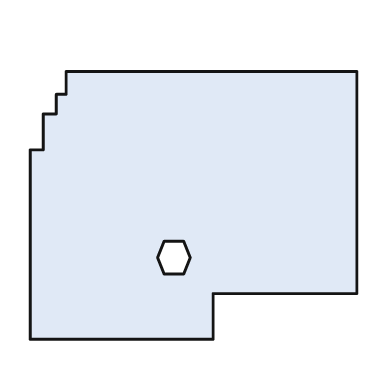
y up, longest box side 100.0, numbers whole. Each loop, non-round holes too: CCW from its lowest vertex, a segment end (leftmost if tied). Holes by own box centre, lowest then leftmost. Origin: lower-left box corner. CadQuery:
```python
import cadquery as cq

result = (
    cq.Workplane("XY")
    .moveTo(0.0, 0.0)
    .lineTo(56.0, 0.0)
    .lineTo(56.0, 14.0)
    .lineTo(100.0, 14.0)
    .lineTo(100.0, 82.0)
    .lineTo(11.0, 82.0)
    .lineTo(11.0, 75.0)
    .lineTo(8.0, 75.0)
    .lineTo(8.0, 69.0)
    .lineTo(4.0, 69.0)
    .lineTo(4.0, 58.0)
    .lineTo(0.0, 58.0)
    .close()
    .moveTo(41.0, 20.0)
    .lineTo(47.0, 20.0)
    .lineTo(49.0, 25.0)
    .lineTo(47.0, 30.0)
    .lineTo(41.0, 30.0)
    .lineTo(39.0, 25.0)
    .close()
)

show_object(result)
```